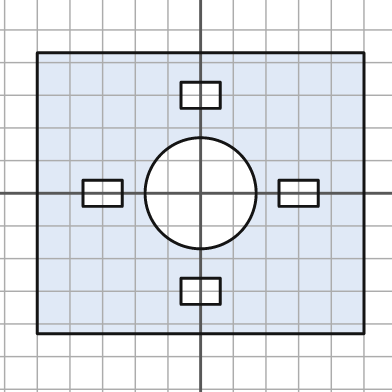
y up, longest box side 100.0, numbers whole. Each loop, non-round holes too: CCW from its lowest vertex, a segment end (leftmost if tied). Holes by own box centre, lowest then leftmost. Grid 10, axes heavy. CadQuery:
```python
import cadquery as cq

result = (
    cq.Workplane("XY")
    .moveTo(-50.0, -43.0)
    .lineTo(50.0, -43.0)
    .lineTo(50.0, 43.0)
    .lineTo(-50.0, 43.0)
    .close()
    .moveTo(-6.0, -34.0)
    .lineTo(6.0, -34.0)
    .lineTo(6.0, -26.0)
    .lineTo(-6.0, -26.0)
    .close()
    .moveTo(-36.0, -4.0)
    .lineTo(-24.0, -4.0)
    .lineTo(-24.0, 4.0)
    .lineTo(-36.0, 4.0)
    .close()
    .moveTo(0.0, 0.0)
    .circle(17.0)
    .moveTo(24.0, -4.0)
    .lineTo(36.0, -4.0)
    .lineTo(36.0, 4.0)
    .lineTo(24.0, 4.0)
    .close()
    .moveTo(-6.0, 26.0)
    .lineTo(6.0, 26.0)
    .lineTo(6.0, 34.0)
    .lineTo(-6.0, 34.0)
    .close()
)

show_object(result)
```